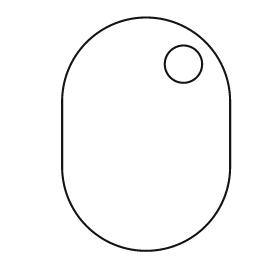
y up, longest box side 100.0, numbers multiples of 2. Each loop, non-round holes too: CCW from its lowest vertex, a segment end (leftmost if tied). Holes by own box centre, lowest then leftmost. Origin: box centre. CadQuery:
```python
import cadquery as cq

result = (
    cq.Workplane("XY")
    .moveTo(-36.0, -14.0)
    .threePointArc((0.0, -50.0), (36.0, -14.0))
    .lineTo(36.0, 14.0)
    .threePointArc((0.0, 50.0), (-36.0, 14.0))
    .close()
    .moveTo(16.0, 30.0)
    .circle(8.0)
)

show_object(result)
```